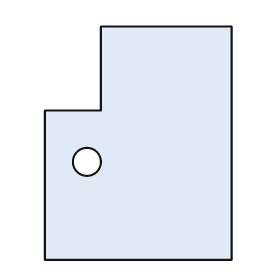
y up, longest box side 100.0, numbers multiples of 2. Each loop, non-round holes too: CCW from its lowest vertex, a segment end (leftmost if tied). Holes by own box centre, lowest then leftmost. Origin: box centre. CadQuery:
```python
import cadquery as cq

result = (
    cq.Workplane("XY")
    .moveTo(-40.0, -50.0)
    .lineTo(40.0, -50.0)
    .lineTo(40.0, 50.0)
    .lineTo(-16.0, 50.0)
    .lineTo(-16.0, 14.0)
    .lineTo(-40.0, 14.0)
    .close()
    .moveTo(-22.0, -8.0)
    .circle(6.0)
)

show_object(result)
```